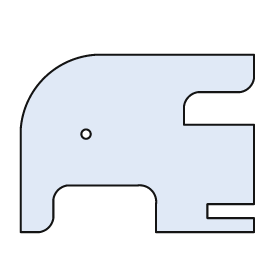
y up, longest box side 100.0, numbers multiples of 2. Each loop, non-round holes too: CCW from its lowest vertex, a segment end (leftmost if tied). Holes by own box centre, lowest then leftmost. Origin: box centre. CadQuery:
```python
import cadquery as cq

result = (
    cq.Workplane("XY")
    .moveTo(-50.0, -38.0)
    .lineTo(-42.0, -38.0)
    .threePointArc((-38.0, -36.0), (-36.0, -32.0))
    .lineTo(-36.0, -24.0)
    .threePointArc((-34.0, -20.0), (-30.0, -18.0))
    .lineTo(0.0, -18.0)
    .threePointArc((6.0, -20.0), (8.0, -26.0))
    .lineTo(8.0, -38.0)
    .lineTo(50.0, -38.0)
    .lineTo(50.0, -32.0)
    .lineTo(30.0, -32.0)
    .lineTo(30.0, -26.0)
    .lineTo(50.0, -26.0)
    .lineTo(50.0, 8.0)
    .lineTo(20.0, 8.0)
    .lineTo(20.0, 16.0)
    .threePointArc((22.0, 20.0), (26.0, 22.0))
    .lineTo(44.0, 22.0)
    .threePointArc((48.0, 24.0), (50.0, 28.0))
    .lineTo(50.0, 38.0)
    .lineTo(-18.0, 38.0)
    .threePointArc((-40.0, 28.0), (-50.0, 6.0))
    .close()
    .moveTo(-22.0, 4.0)
    .circle(2.0)
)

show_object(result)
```